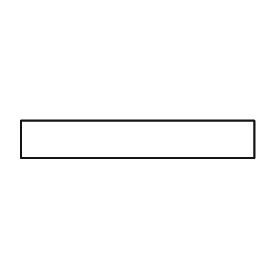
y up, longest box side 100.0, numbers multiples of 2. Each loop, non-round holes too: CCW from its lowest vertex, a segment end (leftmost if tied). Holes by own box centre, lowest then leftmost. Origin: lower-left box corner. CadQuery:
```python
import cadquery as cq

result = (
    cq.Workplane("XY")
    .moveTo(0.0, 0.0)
    .lineTo(100.0, 0.0)
    .lineTo(100.0, 16.0)
    .lineTo(0.0, 16.0)
    .close()
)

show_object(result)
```